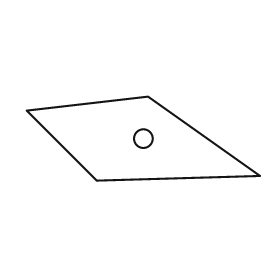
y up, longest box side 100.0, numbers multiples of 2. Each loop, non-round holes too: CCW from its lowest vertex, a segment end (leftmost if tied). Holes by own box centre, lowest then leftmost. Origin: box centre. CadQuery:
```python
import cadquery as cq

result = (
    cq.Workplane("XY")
    .moveTo(-20.0, -18.0)
    .lineTo(50.0, -16.0)
    .lineTo(2.0, 18.0)
    .lineTo(-50.0, 12.0)
    .close()
    .moveTo(0.0, 0.0)
    .circle(4.0)
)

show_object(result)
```